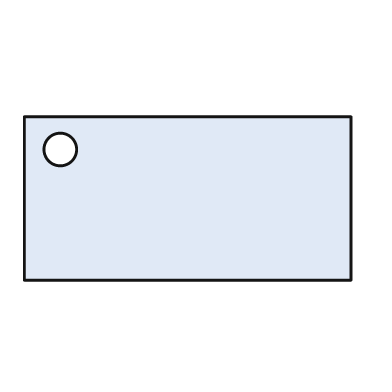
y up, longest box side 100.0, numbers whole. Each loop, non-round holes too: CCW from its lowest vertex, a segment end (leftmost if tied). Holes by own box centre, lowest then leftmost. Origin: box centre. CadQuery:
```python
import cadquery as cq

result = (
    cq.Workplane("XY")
    .moveTo(-50.0, -25.0)
    .lineTo(50.0, -25.0)
    .lineTo(50.0, 25.0)
    .lineTo(-50.0, 25.0)
    .close()
    .moveTo(-39.0, 15.0)
    .circle(5.0)
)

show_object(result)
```